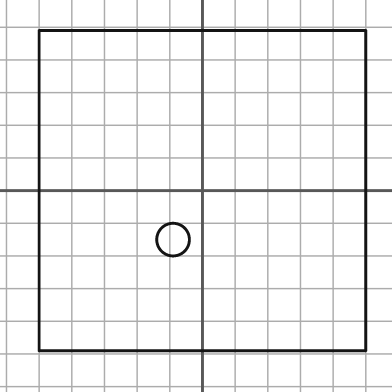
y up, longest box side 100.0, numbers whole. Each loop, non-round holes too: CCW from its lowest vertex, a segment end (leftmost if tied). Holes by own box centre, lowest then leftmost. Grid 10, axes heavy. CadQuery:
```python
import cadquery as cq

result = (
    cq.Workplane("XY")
    .moveTo(-50.0, -49.0)
    .lineTo(50.0, -49.0)
    .lineTo(50.0, 49.0)
    .lineTo(-50.0, 49.0)
    .close()
    .moveTo(-9.0, -15.0)
    .circle(5.0)
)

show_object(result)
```